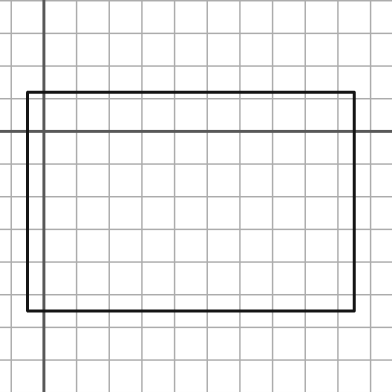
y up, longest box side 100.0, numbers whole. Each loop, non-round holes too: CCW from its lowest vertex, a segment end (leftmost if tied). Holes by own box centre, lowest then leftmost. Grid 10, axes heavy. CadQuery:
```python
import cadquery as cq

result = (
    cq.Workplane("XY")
    .moveTo(-5.0, -55.0)
    .lineTo(95.0, -55.0)
    .lineTo(95.0, 12.0)
    .lineTo(-5.0, 12.0)
    .close()
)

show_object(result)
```